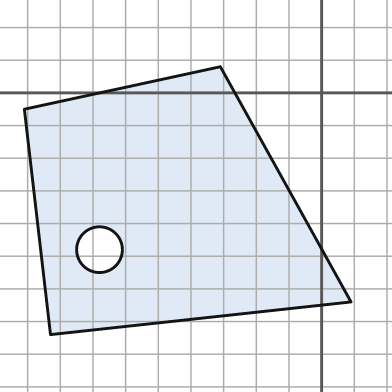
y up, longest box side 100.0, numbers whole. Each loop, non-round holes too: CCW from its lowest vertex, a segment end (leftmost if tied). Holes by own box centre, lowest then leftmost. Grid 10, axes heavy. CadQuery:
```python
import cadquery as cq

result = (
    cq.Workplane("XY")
    .moveTo(-83.0, -74.0)
    .lineTo(9.0, -64.0)
    .lineTo(-31.0, 8.0)
    .lineTo(-91.0, -5.0)
    .close()
    .moveTo(-68.0, -48.0)
    .circle(7.0)
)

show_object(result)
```